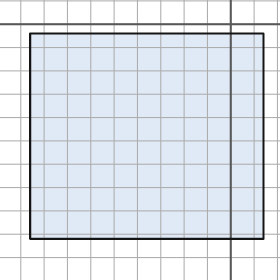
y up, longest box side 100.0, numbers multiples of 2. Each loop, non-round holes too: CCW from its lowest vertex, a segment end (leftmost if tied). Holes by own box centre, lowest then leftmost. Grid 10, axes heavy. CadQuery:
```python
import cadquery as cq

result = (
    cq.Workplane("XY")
    .moveTo(-86.0, -92.0)
    .lineTo(14.0, -92.0)
    .lineTo(14.0, -4.0)
    .lineTo(-86.0, -4.0)
    .close()
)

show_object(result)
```